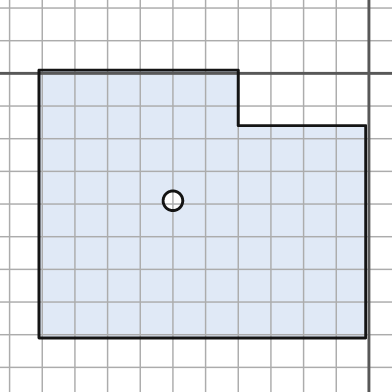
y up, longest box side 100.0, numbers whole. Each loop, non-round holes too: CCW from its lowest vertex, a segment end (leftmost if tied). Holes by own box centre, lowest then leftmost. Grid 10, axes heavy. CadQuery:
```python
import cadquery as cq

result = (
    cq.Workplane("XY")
    .moveTo(-101.0, -81.0)
    .lineTo(-1.0, -81.0)
    .lineTo(-1.0, -16.0)
    .lineTo(-40.0, -16.0)
    .lineTo(-40.0, 1.0)
    .lineTo(-101.0, 1.0)
    .close()
    .moveTo(-60.0, -39.0)
    .circle(3.0)
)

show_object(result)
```